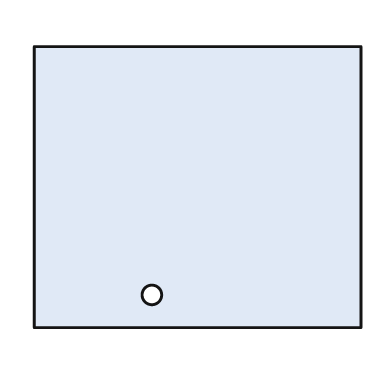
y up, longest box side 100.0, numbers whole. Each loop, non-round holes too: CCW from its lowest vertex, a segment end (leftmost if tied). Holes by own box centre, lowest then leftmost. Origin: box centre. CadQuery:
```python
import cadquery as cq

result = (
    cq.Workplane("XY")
    .moveTo(-50.0, -43.0)
    .lineTo(50.0, -43.0)
    .lineTo(50.0, 43.0)
    .lineTo(-50.0, 43.0)
    .close()
    .moveTo(-14.0, -33.0)
    .circle(3.0)
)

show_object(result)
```